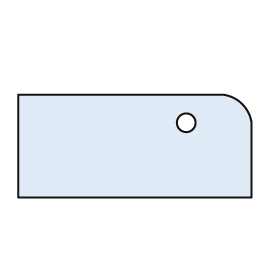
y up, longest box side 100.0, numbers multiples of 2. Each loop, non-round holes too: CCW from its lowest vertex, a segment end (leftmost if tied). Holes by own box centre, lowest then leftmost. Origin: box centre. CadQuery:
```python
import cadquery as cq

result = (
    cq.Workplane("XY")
    .moveTo(-50.0, -22.0)
    .lineTo(50.0, -22.0)
    .lineTo(50.0, 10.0)
    .threePointArc((46.0, 18.0), (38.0, 22.0))
    .lineTo(-50.0, 22.0)
    .close()
    .moveTo(22.0, 10.0)
    .circle(4.0)
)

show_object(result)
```